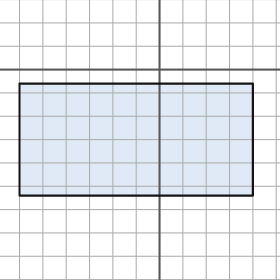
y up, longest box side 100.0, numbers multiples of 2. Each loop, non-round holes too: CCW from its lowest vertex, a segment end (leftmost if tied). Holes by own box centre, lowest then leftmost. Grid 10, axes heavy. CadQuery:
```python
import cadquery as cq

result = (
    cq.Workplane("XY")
    .moveTo(-60.0, -54.0)
    .lineTo(40.0, -54.0)
    .lineTo(40.0, -6.0)
    .lineTo(-60.0, -6.0)
    .close()
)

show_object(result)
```